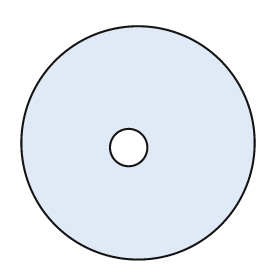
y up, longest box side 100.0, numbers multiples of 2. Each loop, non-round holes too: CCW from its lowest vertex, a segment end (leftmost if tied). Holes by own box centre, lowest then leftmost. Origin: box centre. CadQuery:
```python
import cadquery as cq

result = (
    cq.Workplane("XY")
    .moveTo(0.0, 0.0)
    .circle(50.0)
    .moveTo(-4.0, -2.0)
    .circle(8.0)
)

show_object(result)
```